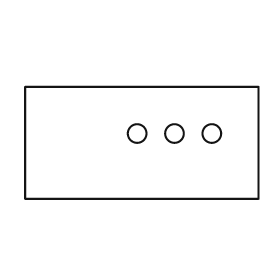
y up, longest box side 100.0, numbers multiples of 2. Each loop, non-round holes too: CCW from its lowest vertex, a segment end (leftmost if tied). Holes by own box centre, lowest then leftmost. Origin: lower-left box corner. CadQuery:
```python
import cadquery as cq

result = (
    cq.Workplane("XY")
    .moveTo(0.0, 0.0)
    .lineTo(100.0, 0.0)
    .lineTo(100.0, 48.0)
    .lineTo(0.0, 48.0)
    .close()
    .moveTo(48.0, 28.0)
    .circle(4.0)
    .moveTo(64.0, 28.0)
    .circle(4.0)
    .moveTo(80.0, 28.0)
    .circle(4.0)
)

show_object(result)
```